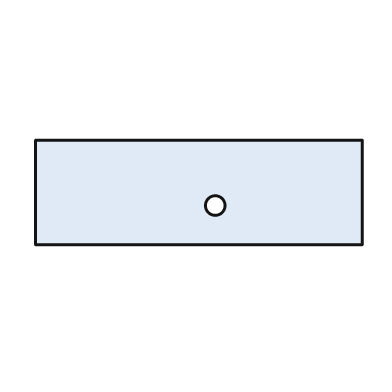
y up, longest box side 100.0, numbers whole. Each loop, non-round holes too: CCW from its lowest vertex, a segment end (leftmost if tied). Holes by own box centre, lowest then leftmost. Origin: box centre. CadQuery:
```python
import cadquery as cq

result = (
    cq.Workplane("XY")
    .moveTo(-50.0, -16.0)
    .lineTo(50.0, -16.0)
    .lineTo(50.0, 16.0)
    .lineTo(-50.0, 16.0)
    .close()
    .moveTo(5.0, -4.0)
    .circle(3.0)
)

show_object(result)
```